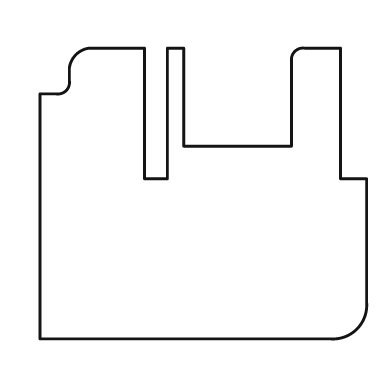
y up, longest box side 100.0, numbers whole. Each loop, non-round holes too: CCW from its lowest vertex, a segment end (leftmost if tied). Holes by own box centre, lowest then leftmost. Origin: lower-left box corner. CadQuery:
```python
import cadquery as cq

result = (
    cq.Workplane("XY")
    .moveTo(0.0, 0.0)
    .lineTo(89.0, 0.0)
    .threePointArc((97.0, 3.0), (100.0, 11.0))
    .lineTo(100.0, 49.0)
    .lineTo(92.0, 49.0)
    .lineTo(92.0, 89.0)
    .lineTo(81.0, 89.0)
    .threePointArc((78.0, 88.0), (77.0, 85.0))
    .lineTo(77.0, 59.0)
    .lineTo(44.0, 59.0)
    .lineTo(44.0, 89.0)
    .lineTo(39.0, 89.0)
    .lineTo(39.0, 49.0)
    .lineTo(32.0, 49.0)
    .lineTo(32.0, 89.0)
    .lineTo(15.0, 89.0)
    .threePointArc((11.0, 87.0), (9.0, 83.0))
    .lineTo(9.0, 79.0)
    .threePointArc((8.0, 76.0), (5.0, 75.0))
    .lineTo(0.0, 75.0)
    .close()
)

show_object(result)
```